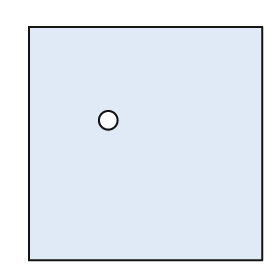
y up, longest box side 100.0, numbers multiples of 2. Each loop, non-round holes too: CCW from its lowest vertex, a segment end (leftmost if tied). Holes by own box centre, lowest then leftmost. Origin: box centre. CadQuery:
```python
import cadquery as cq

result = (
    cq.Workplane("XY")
    .moveTo(-50.0, -50.0)
    .lineTo(50.0, -50.0)
    .lineTo(50.0, 50.0)
    .lineTo(-50.0, 50.0)
    .close()
    .moveTo(-16.0, 10.0)
    .circle(4.0)
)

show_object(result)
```